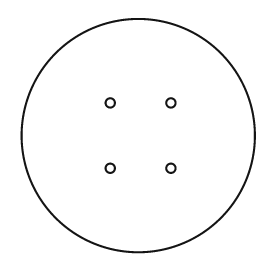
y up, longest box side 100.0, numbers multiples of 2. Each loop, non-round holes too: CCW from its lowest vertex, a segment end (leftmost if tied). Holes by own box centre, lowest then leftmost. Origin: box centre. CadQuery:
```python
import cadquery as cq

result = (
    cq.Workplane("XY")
    .moveTo(0.0, 0.0)
    .circle(50.0)
    .moveTo(-12.0, -14.0)
    .circle(2.0)
    .moveTo(14.0, -14.0)
    .circle(2.0)
    .moveTo(-12.0, 14.0)
    .circle(2.0)
    .moveTo(14.0, 14.0)
    .circle(2.0)
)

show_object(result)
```